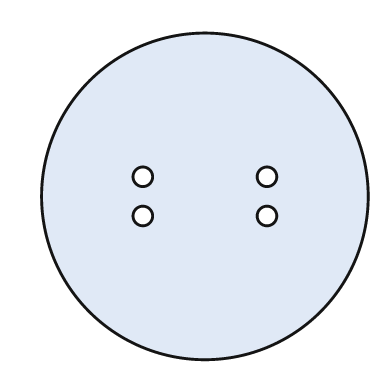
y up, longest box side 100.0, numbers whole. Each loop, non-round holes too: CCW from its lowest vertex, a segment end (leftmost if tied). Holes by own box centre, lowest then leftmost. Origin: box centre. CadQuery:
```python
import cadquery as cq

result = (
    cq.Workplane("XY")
    .moveTo(0.0, 0.0)
    .circle(50.0)
    .moveTo(-19.0, -6.0)
    .circle(3.0)
    .moveTo(19.0, -6.0)
    .circle(3.0)
    .moveTo(-19.0, 6.0)
    .circle(3.0)
    .moveTo(19.0, 6.0)
    .circle(3.0)
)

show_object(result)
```